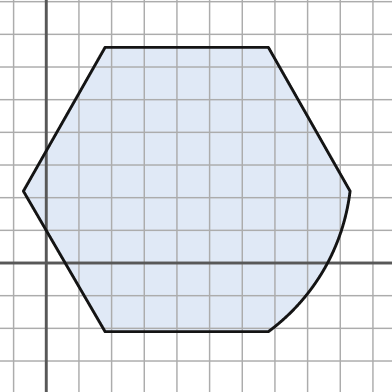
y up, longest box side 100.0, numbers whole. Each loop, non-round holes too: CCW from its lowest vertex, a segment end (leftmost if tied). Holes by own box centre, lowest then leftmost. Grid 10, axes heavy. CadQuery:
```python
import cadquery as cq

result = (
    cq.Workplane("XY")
    .moveTo(18.0, -21.0)
    .lineTo(68.0, -21.0)
    .threePointArc((85.0, -2.0), (93.0, 22.0))
    .lineTo(68.0, 66.0)
    .lineTo(18.0, 66.0)
    .lineTo(-7.0, 22.0)
    .close()
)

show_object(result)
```